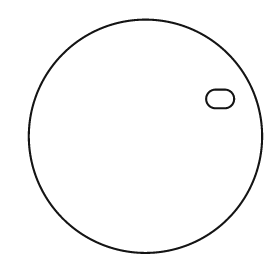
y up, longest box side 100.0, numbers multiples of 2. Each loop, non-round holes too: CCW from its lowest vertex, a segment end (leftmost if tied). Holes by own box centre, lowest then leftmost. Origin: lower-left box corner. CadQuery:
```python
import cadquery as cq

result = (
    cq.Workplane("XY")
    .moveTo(50.0, 50.0)
    .circle(50.0)
    .moveTo(80.0, 62.0)
    .lineTo(84.0, 62.0)
    .threePointArc((88.0, 66.0), (84.0, 70.0))
    .lineTo(80.0, 70.0)
    .threePointArc((76.0, 66.0), (80.0, 62.0))
    .close()
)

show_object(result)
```